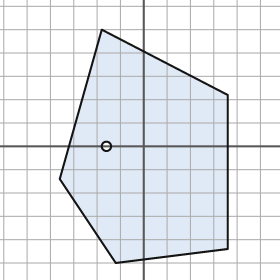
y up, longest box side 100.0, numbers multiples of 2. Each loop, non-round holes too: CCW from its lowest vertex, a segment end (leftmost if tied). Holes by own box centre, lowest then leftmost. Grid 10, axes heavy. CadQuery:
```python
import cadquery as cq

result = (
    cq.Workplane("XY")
    .moveTo(-12.0, -50.0)
    .lineTo(36.0, -44.0)
    .lineTo(36.0, 22.0)
    .lineTo(-18.0, 50.0)
    .lineTo(-36.0, -14.0)
    .close()
    .moveTo(-16.0, 0.0)
    .circle(2.0)
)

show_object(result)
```